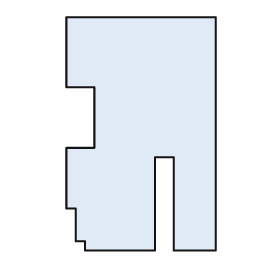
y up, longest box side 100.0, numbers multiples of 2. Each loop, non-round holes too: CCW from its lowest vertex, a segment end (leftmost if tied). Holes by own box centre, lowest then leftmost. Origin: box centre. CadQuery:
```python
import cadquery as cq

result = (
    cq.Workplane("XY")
    .moveTo(-24.0, -50.0)
    .lineTo(6.0, -50.0)
    .lineTo(6.0, -10.0)
    .lineTo(14.0, -10.0)
    .lineTo(14.0, -50.0)
    .lineTo(32.0, -50.0)
    .lineTo(32.0, 50.0)
    .lineTo(-32.0, 50.0)
    .lineTo(-32.0, 20.0)
    .lineTo(-20.0, 20.0)
    .lineTo(-20.0, -6.0)
    .lineTo(-32.0, -6.0)
    .lineTo(-32.0, -32.0)
    .lineTo(-28.0, -32.0)
    .lineTo(-28.0, -46.0)
    .lineTo(-24.0, -46.0)
    .close()
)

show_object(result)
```